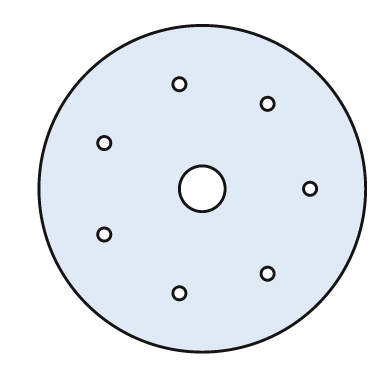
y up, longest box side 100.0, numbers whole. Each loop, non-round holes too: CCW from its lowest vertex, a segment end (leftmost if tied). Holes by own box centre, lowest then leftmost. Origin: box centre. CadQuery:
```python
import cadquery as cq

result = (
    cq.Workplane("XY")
    .moveTo(0.0, 0.0)
    .circle(50.0)
    .moveTo(-7.0, -32.0)
    .circle(2.0)
    .moveTo(20.0, -26.0)
    .circle(2.0)
    .moveTo(-30.0, -14.0)
    .circle(2.0)
    .moveTo(0.0, 0.0)
    .circle(7.0)
    .moveTo(33.0, 0.0)
    .circle(2.0)
    .moveTo(-30.0, 14.0)
    .circle(2.0)
    .moveTo(20.0, 26.0)
    .circle(2.0)
    .moveTo(-7.0, 32.0)
    .circle(2.0)
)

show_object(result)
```